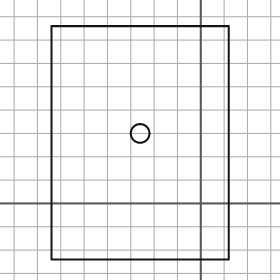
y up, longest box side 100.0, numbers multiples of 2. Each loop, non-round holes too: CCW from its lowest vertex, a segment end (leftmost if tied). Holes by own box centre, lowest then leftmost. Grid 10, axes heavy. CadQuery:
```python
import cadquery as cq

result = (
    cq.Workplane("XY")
    .moveTo(-64.0, -24.0)
    .lineTo(12.0, -24.0)
    .lineTo(12.0, 76.0)
    .lineTo(-64.0, 76.0)
    .close()
    .moveTo(-26.0, 30.0)
    .circle(4.0)
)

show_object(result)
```